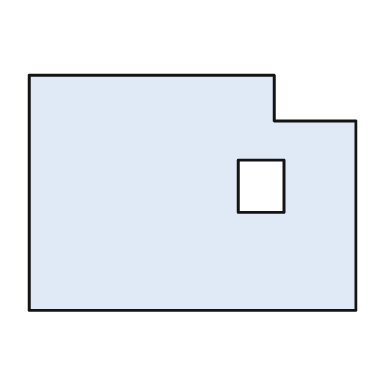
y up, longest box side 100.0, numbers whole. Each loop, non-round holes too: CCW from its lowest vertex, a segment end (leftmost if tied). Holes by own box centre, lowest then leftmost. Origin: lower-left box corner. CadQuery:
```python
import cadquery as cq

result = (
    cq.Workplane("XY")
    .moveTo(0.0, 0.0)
    .lineTo(100.0, 0.0)
    .lineTo(100.0, 58.0)
    .lineTo(75.0, 58.0)
    .lineTo(75.0, 72.0)
    .lineTo(0.0, 72.0)
    .close()
    .moveTo(64.0, 30.0)
    .lineTo(78.0, 30.0)
    .lineTo(78.0, 46.0)
    .lineTo(64.0, 46.0)
    .close()
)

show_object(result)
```